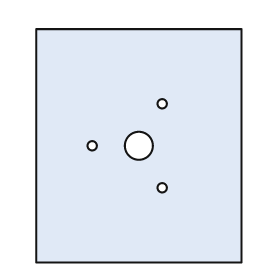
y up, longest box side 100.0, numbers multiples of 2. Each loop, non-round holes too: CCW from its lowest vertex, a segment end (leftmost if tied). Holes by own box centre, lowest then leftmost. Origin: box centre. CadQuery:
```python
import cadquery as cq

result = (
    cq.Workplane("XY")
    .moveTo(-44.0, -50.0)
    .lineTo(44.0, -50.0)
    .lineTo(44.0, 50.0)
    .lineTo(-44.0, 50.0)
    .close()
    .moveTo(10.0, -18.0)
    .circle(2.0)
    .moveTo(-20.0, 0.0)
    .circle(2.0)
    .moveTo(0.0, 0.0)
    .circle(6.0)
    .moveTo(10.0, 18.0)
    .circle(2.0)
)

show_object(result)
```